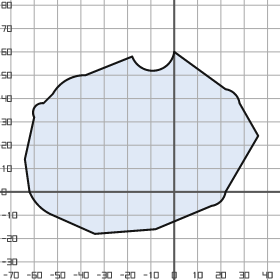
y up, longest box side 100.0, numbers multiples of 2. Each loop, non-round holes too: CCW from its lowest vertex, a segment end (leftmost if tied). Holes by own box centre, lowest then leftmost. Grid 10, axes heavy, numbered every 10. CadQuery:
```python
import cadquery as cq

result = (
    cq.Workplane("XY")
    .moveTo(-34.0, -18.0)
    .lineTo(-8.0, -16.0)
    .lineTo(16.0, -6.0)
    .threePointArc((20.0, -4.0), (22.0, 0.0))
    .lineTo(36.0, 24.0)
    .lineTo(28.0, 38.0)
    .threePointArc((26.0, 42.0), (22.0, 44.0))
    .lineTo(0.0, 60.0)
    .threePointArc((-8.0, 52.0), (-18.0, 58.0))
    .lineTo(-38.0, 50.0)
    .threePointArc((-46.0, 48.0), (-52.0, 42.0))
    .lineTo(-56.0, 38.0)
    .threePointArc((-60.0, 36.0), (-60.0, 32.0))
    .lineTo(-64.0, 14.0)
    .lineTo(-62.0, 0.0)
    .threePointArc((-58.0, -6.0), (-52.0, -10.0))
    .close()
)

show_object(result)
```